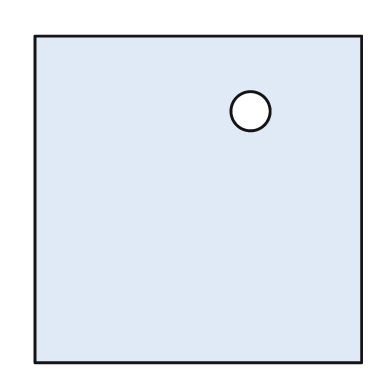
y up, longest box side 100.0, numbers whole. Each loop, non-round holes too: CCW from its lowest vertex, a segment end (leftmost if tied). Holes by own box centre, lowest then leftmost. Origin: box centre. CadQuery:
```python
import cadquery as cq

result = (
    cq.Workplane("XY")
    .moveTo(-50.0, -50.0)
    .lineTo(50.0, -50.0)
    .lineTo(50.0, 50.0)
    .lineTo(-50.0, 50.0)
    .close()
    .moveTo(16.0, 27.0)
    .circle(6.0)
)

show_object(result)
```